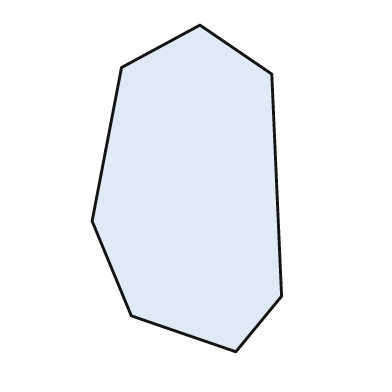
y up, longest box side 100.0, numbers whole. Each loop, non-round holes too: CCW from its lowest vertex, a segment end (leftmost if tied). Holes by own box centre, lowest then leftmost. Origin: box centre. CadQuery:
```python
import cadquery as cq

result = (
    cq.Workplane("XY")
    .moveTo(15.0, -50.0)
    .lineTo(29.0, -33.0)
    .lineTo(26.0, 35.0)
    .lineTo(4.0, 50.0)
    .lineTo(-20.0, 37.0)
    .lineTo(-29.0, -10.0)
    .lineTo(-17.0, -39.0)
    .close()
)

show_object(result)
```